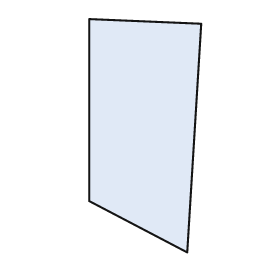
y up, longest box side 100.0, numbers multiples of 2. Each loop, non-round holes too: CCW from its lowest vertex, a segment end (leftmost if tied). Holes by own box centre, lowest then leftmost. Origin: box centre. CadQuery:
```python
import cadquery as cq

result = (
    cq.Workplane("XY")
    .moveTo(18.0, -50.0)
    .lineTo(24.0, 48.0)
    .lineTo(-24.0, 50.0)
    .lineTo(-24.0, -28.0)
    .close()
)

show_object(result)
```